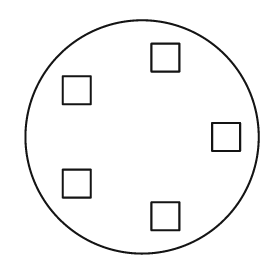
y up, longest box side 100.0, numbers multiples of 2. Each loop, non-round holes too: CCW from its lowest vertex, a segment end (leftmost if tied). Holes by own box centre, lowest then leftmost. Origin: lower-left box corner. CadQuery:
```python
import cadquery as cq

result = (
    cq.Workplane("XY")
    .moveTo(50.0, 50.0)
    .circle(50.0)
    .moveTo(54.0, 10.0)
    .lineTo(66.0, 10.0)
    .lineTo(66.0, 22.0)
    .lineTo(54.0, 22.0)
    .close()
    .moveTo(16.0, 24.0)
    .lineTo(28.0, 24.0)
    .lineTo(28.0, 36.0)
    .lineTo(16.0, 36.0)
    .close()
    .moveTo(80.0, 44.0)
    .lineTo(92.0, 44.0)
    .lineTo(92.0, 56.0)
    .lineTo(80.0, 56.0)
    .close()
    .moveTo(16.0, 64.0)
    .lineTo(28.0, 64.0)
    .lineTo(28.0, 76.0)
    .lineTo(16.0, 76.0)
    .close()
    .moveTo(54.0, 78.0)
    .lineTo(66.0, 78.0)
    .lineTo(66.0, 90.0)
    .lineTo(54.0, 90.0)
    .close()
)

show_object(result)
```